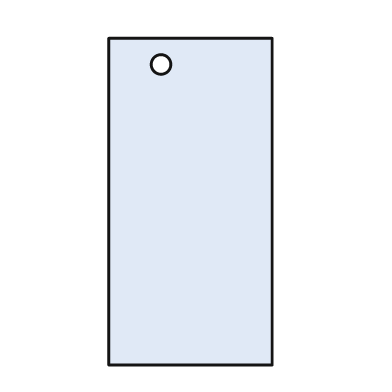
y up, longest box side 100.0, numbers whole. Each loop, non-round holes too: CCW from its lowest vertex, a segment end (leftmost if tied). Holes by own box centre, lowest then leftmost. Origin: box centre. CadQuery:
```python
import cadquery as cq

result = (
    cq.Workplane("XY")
    .moveTo(-25.0, -50.0)
    .lineTo(25.0, -50.0)
    .lineTo(25.0, 50.0)
    .lineTo(-25.0, 50.0)
    .close()
    .moveTo(-9.0, 42.0)
    .circle(3.0)
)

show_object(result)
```